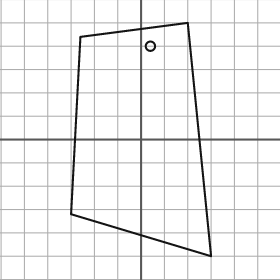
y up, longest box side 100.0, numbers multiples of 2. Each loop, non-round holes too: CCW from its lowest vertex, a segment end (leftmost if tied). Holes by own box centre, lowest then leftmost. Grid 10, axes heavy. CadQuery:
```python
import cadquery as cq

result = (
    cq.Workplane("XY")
    .moveTo(30.0, -50.0)
    .lineTo(20.0, 50.0)
    .lineTo(-26.0, 44.0)
    .lineTo(-30.0, -32.0)
    .close()
    .moveTo(4.0, 40.0)
    .circle(2.0)
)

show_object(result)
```